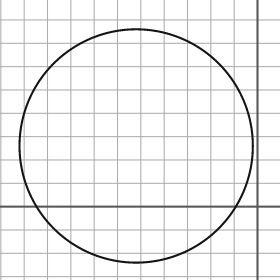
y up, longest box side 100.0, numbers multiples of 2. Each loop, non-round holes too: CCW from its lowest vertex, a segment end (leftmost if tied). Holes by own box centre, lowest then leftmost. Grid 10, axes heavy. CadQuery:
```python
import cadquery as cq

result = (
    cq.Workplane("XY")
    .moveTo(-52.0, 26.0)
    .circle(50.0)
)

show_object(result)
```